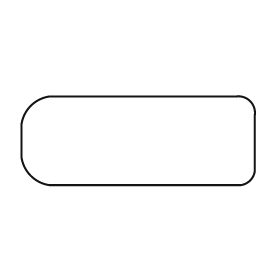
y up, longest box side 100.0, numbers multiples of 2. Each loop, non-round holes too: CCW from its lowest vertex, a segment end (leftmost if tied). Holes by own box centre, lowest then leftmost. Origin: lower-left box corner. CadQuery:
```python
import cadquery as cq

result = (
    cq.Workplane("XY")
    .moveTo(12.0, 0.0)
    .lineTo(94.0, 0.0)
    .threePointArc((98.0, 2.0), (100.0, 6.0))
    .lineTo(100.0, 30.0)
    .threePointArc((98.0, 36.0), (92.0, 38.0))
    .lineTo(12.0, 38.0)
    .threePointArc((4.0, 34.0), (0.0, 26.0))
    .lineTo(0.0, 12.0)
    .threePointArc((4.0, 4.0), (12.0, 0.0))
    .close()
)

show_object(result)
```